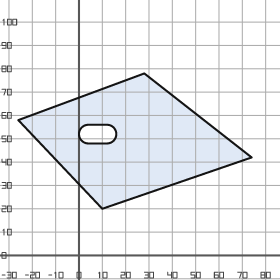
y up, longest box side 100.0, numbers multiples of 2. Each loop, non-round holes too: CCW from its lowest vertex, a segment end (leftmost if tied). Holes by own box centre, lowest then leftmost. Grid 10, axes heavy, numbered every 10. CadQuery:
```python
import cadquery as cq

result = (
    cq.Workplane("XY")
    .moveTo(10.0, 20.0)
    .lineTo(74.0, 42.0)
    .lineTo(28.0, 78.0)
    .lineTo(-26.0, 58.0)
    .close()
    .moveTo(4.0, 48.0)
    .lineTo(12.0, 48.0)
    .threePointArc((16.0, 52.0), (12.0, 56.0))
    .lineTo(4.0, 56.0)
    .threePointArc((0.0, 52.0), (4.0, 48.0))
    .close()
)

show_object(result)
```